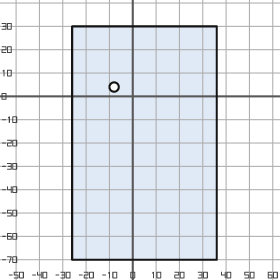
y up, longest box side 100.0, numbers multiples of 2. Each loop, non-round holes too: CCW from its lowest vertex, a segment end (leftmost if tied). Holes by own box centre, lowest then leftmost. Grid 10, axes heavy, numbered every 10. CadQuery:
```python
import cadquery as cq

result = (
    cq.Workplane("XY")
    .moveTo(-26.0, -70.0)
    .lineTo(36.0, -70.0)
    .lineTo(36.0, 30.0)
    .lineTo(-26.0, 30.0)
    .close()
    .moveTo(-8.0, 4.0)
    .circle(2.0)
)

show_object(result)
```